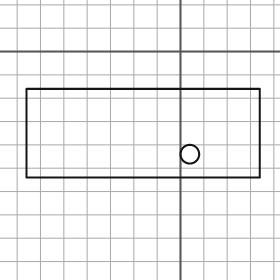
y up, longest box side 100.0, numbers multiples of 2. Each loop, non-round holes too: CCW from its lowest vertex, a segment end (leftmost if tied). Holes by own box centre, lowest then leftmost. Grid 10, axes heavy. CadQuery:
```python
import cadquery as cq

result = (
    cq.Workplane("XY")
    .moveTo(-66.0, -54.0)
    .lineTo(34.0, -54.0)
    .lineTo(34.0, -16.0)
    .lineTo(-66.0, -16.0)
    .close()
    .moveTo(4.0, -44.0)
    .circle(4.0)
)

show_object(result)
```